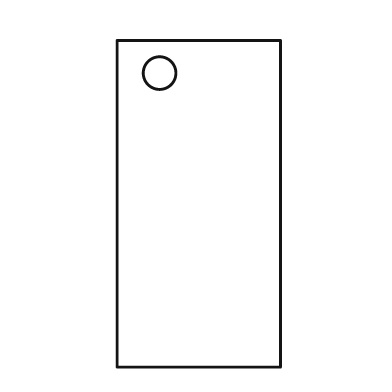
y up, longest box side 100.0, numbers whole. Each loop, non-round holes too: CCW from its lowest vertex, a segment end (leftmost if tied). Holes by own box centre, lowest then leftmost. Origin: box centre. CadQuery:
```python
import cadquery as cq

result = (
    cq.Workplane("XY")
    .moveTo(-25.0, -50.0)
    .lineTo(25.0, -50.0)
    .lineTo(25.0, 50.0)
    .lineTo(-25.0, 50.0)
    .close()
    .moveTo(-12.0, 40.0)
    .circle(5.0)
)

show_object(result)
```